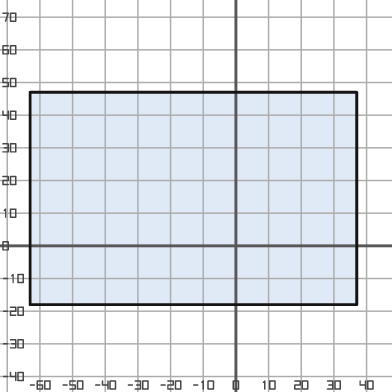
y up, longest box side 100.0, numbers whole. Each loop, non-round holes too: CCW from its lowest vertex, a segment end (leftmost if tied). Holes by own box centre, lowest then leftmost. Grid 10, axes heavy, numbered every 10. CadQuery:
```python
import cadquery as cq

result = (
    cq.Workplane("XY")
    .moveTo(-63.0, -18.0)
    .lineTo(37.0, -18.0)
    .lineTo(37.0, 47.0)
    .lineTo(-63.0, 47.0)
    .close()
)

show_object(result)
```